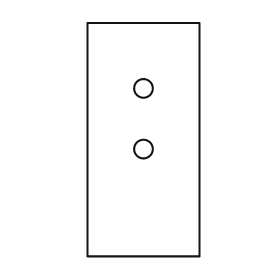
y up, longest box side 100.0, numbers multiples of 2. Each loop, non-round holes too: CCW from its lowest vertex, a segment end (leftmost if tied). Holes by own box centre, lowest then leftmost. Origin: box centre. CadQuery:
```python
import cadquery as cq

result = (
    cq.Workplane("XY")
    .moveTo(-24.0, -50.0)
    .lineTo(24.0, -50.0)
    .lineTo(24.0, 50.0)
    .lineTo(-24.0, 50.0)
    .close()
    .moveTo(0.0, -4.0)
    .circle(4.0)
    .moveTo(0.0, 22.0)
    .circle(4.0)
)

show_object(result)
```